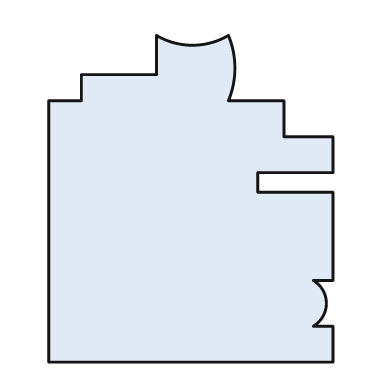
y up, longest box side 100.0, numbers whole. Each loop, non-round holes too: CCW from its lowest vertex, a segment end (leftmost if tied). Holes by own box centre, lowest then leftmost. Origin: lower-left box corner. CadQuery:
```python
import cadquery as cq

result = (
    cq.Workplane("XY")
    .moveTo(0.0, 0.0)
    .lineTo(87.0, 0.0)
    .lineTo(87.0, 11.0)
    .lineTo(81.0, 11.0)
    .threePointArc((85.0, 18.0), (81.0, 25.0))
    .lineTo(87.0, 25.0)
    .lineTo(87.0, 52.0)
    .lineTo(64.0, 52.0)
    .lineTo(64.0, 58.0)
    .lineTo(87.0, 58.0)
    .lineTo(87.0, 69.0)
    .lineTo(72.0, 69.0)
    .lineTo(72.0, 80.0)
    .lineTo(55.0, 80.0)
    .threePointArc((57.0, 90.0), (55.0, 100.0))
    .threePointArc((44.0, 97.0), (33.0, 100.0))
    .lineTo(33.0, 88.0)
    .lineTo(10.0, 88.0)
    .lineTo(10.0, 80.0)
    .lineTo(0.0, 80.0)
    .close()
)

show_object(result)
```